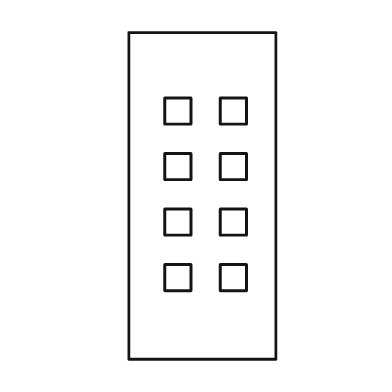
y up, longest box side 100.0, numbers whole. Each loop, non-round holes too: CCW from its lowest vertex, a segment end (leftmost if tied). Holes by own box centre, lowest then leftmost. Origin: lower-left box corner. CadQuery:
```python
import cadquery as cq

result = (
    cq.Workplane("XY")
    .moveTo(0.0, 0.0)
    .lineTo(45.0, 0.0)
    .lineTo(45.0, 100.0)
    .lineTo(0.0, 100.0)
    .close()
    .moveTo(11.0, 21.0)
    .lineTo(19.0, 21.0)
    .lineTo(19.0, 29.0)
    .lineTo(11.0, 29.0)
    .close()
    .moveTo(28.0, 21.0)
    .lineTo(36.0, 21.0)
    .lineTo(36.0, 29.0)
    .lineTo(28.0, 29.0)
    .close()
    .moveTo(11.0, 38.0)
    .lineTo(19.0, 38.0)
    .lineTo(19.0, 46.0)
    .lineTo(11.0, 46.0)
    .close()
    .moveTo(28.0, 38.0)
    .lineTo(36.0, 38.0)
    .lineTo(36.0, 46.0)
    .lineTo(28.0, 46.0)
    .close()
    .moveTo(11.0, 55.0)
    .lineTo(19.0, 55.0)
    .lineTo(19.0, 63.0)
    .lineTo(11.0, 63.0)
    .close()
    .moveTo(28.0, 55.0)
    .lineTo(36.0, 55.0)
    .lineTo(36.0, 63.0)
    .lineTo(28.0, 63.0)
    .close()
    .moveTo(11.0, 72.0)
    .lineTo(19.0, 72.0)
    .lineTo(19.0, 80.0)
    .lineTo(11.0, 80.0)
    .close()
    .moveTo(28.0, 72.0)
    .lineTo(36.0, 72.0)
    .lineTo(36.0, 80.0)
    .lineTo(28.0, 80.0)
    .close()
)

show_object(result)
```